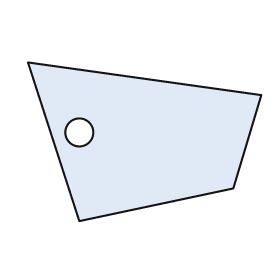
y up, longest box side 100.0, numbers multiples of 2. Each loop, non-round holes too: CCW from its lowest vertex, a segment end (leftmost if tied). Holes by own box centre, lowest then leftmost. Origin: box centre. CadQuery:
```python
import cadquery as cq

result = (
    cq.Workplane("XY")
    .moveTo(-28.0, -34.0)
    .lineTo(38.0, -20.0)
    .lineTo(50.0, 20.0)
    .lineTo(-50.0, 34.0)
    .close()
    .moveTo(-28.0, 4.0)
    .circle(6.0)
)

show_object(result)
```